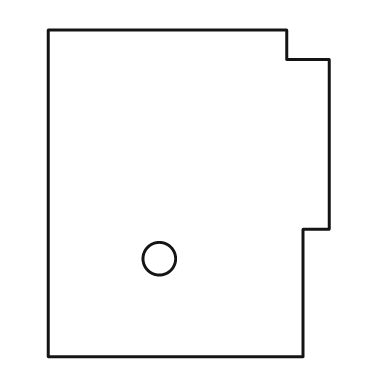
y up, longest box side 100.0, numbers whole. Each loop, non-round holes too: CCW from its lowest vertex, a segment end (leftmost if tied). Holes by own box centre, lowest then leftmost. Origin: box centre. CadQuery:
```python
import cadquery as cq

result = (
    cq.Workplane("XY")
    .moveTo(-43.0, -50.0)
    .lineTo(35.0, -50.0)
    .lineTo(35.0, -11.0)
    .lineTo(43.0, -11.0)
    .lineTo(43.0, 41.0)
    .lineTo(30.0, 41.0)
    .lineTo(30.0, 50.0)
    .lineTo(-43.0, 50.0)
    .close()
    .moveTo(-9.0, -20.0)
    .circle(5.0)
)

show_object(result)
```